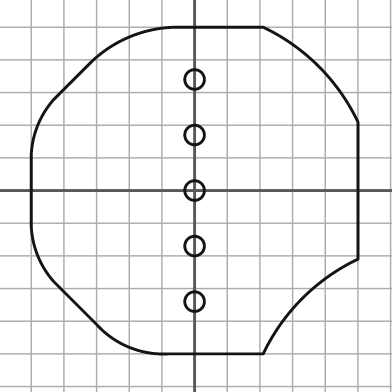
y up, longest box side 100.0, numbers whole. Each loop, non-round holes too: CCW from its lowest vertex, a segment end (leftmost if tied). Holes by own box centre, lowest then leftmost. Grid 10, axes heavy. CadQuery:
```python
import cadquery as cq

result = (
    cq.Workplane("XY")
    .moveTo(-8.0, -50.0)
    .lineTo(21.0, -50.0)
    .threePointArc((33.0, -33.0), (50.0, -21.0))
    .lineTo(50.0, 21.0)
    .threePointArc((38.0, 38.0), (21.0, 50.0))
    .lineTo(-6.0, 50.0)
    .threePointArc((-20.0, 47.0), (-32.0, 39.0))
    .lineTo(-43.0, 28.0)
    .threePointArc((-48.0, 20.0), (-50.0, 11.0))
    .lineTo(-50.0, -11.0)
    .threePointArc((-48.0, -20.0), (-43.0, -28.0))
    .lineTo(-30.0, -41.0)
    .threePointArc((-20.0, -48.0), (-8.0, -50.0))
    .close()
    .moveTo(0.0, -34.0)
    .circle(3.0)
    .moveTo(0.0, -17.0)
    .circle(3.0)
    .moveTo(0.0, 0.0)
    .circle(3.0)
    .moveTo(0.0, 17.0)
    .circle(3.0)
    .moveTo(0.0, 34.0)
    .circle(3.0)
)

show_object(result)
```